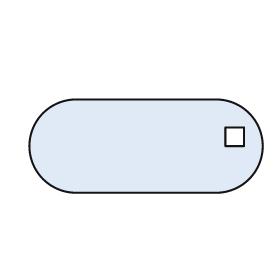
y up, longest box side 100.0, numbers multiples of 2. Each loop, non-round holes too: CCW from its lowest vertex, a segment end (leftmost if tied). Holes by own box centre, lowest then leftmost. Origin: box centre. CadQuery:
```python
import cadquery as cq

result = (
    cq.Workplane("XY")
    .moveTo(-30.0, -20.0)
    .lineTo(30.0, -20.0)
    .threePointArc((50.0, 0.0), (30.0, 20.0))
    .lineTo(-30.0, 20.0)
    .threePointArc((-50.0, 0.0), (-30.0, -20.0))
    .close()
    .moveTo(34.0, 0.0)
    .lineTo(42.0, 0.0)
    .lineTo(42.0, 8.0)
    .lineTo(34.0, 8.0)
    .close()
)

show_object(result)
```